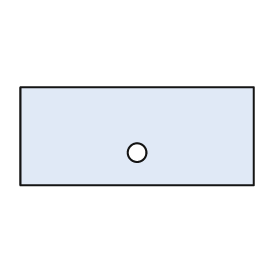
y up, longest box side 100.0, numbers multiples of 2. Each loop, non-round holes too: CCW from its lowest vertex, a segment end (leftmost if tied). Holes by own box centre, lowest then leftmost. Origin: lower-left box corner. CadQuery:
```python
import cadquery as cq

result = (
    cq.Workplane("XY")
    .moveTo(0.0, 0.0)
    .lineTo(100.0, 0.0)
    .lineTo(100.0, 42.0)
    .lineTo(0.0, 42.0)
    .close()
    .moveTo(50.0, 14.0)
    .circle(4.0)
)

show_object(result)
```